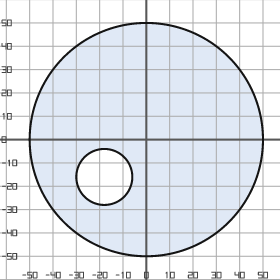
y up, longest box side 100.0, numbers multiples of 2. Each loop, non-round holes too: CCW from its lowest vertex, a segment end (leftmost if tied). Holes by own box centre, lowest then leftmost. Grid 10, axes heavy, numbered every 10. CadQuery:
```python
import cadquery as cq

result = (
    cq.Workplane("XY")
    .moveTo(0.0, 0.0)
    .circle(50.0)
    .moveTo(-18.0, -16.0)
    .circle(12.0)
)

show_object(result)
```